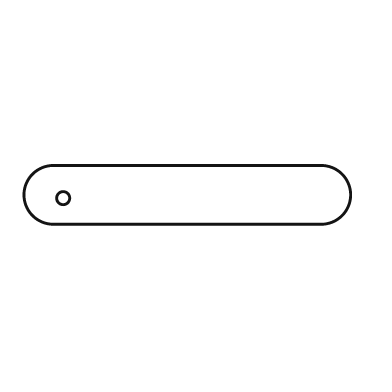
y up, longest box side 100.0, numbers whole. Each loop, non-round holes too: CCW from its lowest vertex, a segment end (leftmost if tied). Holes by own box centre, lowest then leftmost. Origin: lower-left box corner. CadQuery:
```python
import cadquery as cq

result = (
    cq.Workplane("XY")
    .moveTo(9.0, 0.0)
    .lineTo(91.0, 0.0)
    .threePointArc((100.0, 9.0), (91.0, 18.0))
    .lineTo(9.0, 18.0)
    .threePointArc((0.0, 9.0), (9.0, 0.0))
    .close()
    .moveTo(12.0, 8.0)
    .circle(2.0)
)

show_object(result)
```